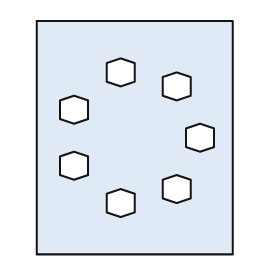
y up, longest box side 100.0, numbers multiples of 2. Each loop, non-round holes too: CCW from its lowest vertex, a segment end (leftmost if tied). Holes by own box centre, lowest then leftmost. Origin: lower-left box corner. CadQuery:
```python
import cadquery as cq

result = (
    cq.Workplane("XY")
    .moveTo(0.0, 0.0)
    .lineTo(84.0, 0.0)
    .lineTo(84.0, 100.0)
    .lineTo(0.0, 100.0)
    .close()
    .moveTo(36.0, 16.0)
    .lineTo(42.0, 18.0)
    .lineTo(42.0, 26.0)
    .lineTo(36.0, 28.0)
    .lineTo(30.0, 26.0)
    .lineTo(30.0, 18.0)
    .close()
    .moveTo(60.0, 22.0)
    .lineTo(66.0, 24.0)
    .lineTo(66.0, 32.0)
    .lineTo(60.0, 34.0)
    .lineTo(54.0, 32.0)
    .lineTo(54.0, 24.0)
    .close()
    .moveTo(16.0, 32.0)
    .lineTo(22.0, 34.0)
    .lineTo(22.0, 42.0)
    .lineTo(16.0, 44.0)
    .lineTo(10.0, 42.0)
    .lineTo(10.0, 34.0)
    .close()
    .moveTo(70.0, 44.0)
    .lineTo(76.0, 46.0)
    .lineTo(76.0, 54.0)
    .lineTo(70.0, 56.0)
    .lineTo(64.0, 54.0)
    .lineTo(64.0, 46.0)
    .close()
    .moveTo(16.0, 56.0)
    .lineTo(22.0, 58.0)
    .lineTo(22.0, 66.0)
    .lineTo(16.0, 68.0)
    .lineTo(10.0, 66.0)
    .lineTo(10.0, 58.0)
    .close()
    .moveTo(60.0, 66.0)
    .lineTo(66.0, 68.0)
    .lineTo(66.0, 76.0)
    .lineTo(60.0, 78.0)
    .lineTo(54.0, 76.0)
    .lineTo(54.0, 68.0)
    .close()
    .moveTo(36.0, 72.0)
    .lineTo(42.0, 74.0)
    .lineTo(42.0, 82.0)
    .lineTo(36.0, 84.0)
    .lineTo(30.0, 82.0)
    .lineTo(30.0, 74.0)
    .close()
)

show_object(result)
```